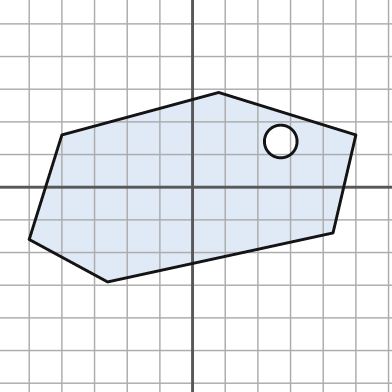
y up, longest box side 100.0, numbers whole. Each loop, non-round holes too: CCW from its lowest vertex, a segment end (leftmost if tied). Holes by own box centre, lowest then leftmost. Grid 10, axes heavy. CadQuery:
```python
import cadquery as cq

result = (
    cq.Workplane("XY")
    .moveTo(-26.0, -29.0)
    .lineTo(43.0, -14.0)
    .lineTo(50.0, 16.0)
    .lineTo(8.0, 29.0)
    .lineTo(-40.0, 16.0)
    .lineTo(-50.0, -16.0)
    .close()
    .moveTo(27.0, 14.0)
    .circle(5.0)
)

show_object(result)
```